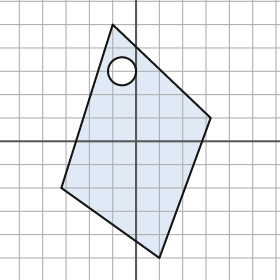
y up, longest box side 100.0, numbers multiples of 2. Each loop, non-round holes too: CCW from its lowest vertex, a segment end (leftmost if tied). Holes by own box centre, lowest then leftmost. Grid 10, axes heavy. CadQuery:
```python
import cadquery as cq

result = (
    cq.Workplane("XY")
    .moveTo(10.0, -50.0)
    .lineTo(32.0, 10.0)
    .lineTo(-10.0, 50.0)
    .lineTo(-32.0, -20.0)
    .close()
    .moveTo(-6.0, 30.0)
    .circle(6.0)
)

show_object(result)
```